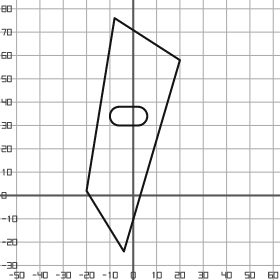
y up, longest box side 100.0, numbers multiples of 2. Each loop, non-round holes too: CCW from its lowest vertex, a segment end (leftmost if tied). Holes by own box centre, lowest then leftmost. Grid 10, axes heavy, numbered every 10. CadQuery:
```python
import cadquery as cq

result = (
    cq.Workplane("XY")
    .moveTo(-4.0, -24.0)
    .lineTo(20.0, 58.0)
    .lineTo(-8.0, 76.0)
    .lineTo(-20.0, 2.0)
    .close()
    .moveTo(-6.0, 30.0)
    .lineTo(2.0, 30.0)
    .threePointArc((6.0, 34.0), (2.0, 38.0))
    .lineTo(-6.0, 38.0)
    .threePointArc((-10.0, 34.0), (-6.0, 30.0))
    .close()
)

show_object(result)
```